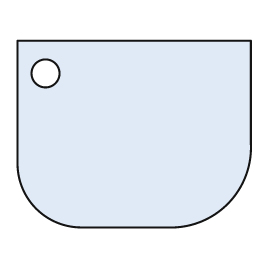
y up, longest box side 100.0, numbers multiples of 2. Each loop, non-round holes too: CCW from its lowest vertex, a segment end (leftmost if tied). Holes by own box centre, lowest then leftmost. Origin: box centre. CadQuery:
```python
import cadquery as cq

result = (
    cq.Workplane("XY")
    .moveTo(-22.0, -40.0)
    .lineTo(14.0, -40.0)
    .threePointArc((40.0, -30.0), (50.0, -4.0))
    .lineTo(50.0, 40.0)
    .lineTo(-50.0, 40.0)
    .lineTo(-50.0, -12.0)
    .threePointArc((-42.0, -32.0), (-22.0, -40.0))
    .close()
    .moveTo(-38.0, 26.0)
    .circle(6.0)
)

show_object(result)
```